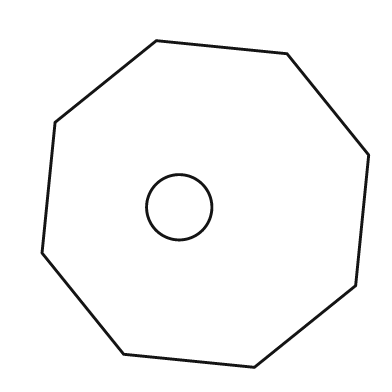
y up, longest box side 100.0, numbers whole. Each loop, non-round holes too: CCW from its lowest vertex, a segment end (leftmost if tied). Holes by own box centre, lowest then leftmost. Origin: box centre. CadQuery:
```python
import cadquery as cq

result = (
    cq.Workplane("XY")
    .moveTo(15.0, -50.0)
    .lineTo(46.0, -25.0)
    .lineTo(50.0, 15.0)
    .lineTo(25.0, 46.0)
    .lineTo(-15.0, 50.0)
    .lineTo(-46.0, 25.0)
    .lineTo(-50.0, -15.0)
    .lineTo(-25.0, -46.0)
    .close()
    .moveTo(-8.0, -1.0)
    .circle(10.0)
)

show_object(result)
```